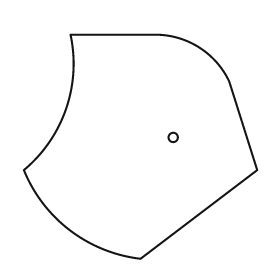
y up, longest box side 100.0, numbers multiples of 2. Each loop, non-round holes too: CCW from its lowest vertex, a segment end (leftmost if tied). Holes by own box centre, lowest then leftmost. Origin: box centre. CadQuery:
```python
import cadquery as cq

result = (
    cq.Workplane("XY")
    .moveTo(0.0, -48.0)
    .lineTo(50.0, -10.0)
    .lineTo(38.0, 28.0)
    .threePointArc((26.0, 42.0), (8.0, 48.0))
    .lineTo(-30.0, 48.0)
    .threePointArc((-32.0, 16.0), (-50.0, -10.0))
    .threePointArc((-30.0, -36.0), (0.0, -48.0))
    .close()
    .moveTo(14.0, 4.0)
    .circle(2.0)
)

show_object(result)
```